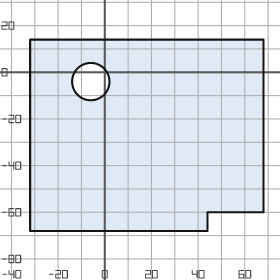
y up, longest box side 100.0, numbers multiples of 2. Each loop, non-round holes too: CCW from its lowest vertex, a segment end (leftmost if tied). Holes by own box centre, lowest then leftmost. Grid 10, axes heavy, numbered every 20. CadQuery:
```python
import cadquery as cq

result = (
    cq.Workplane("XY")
    .moveTo(-32.0, -68.0)
    .lineTo(44.0, -68.0)
    .lineTo(44.0, -60.0)
    .lineTo(68.0, -60.0)
    .lineTo(68.0, 14.0)
    .lineTo(-32.0, 14.0)
    .close()
    .moveTo(-6.0, -4.0)
    .circle(8.0)
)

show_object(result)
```